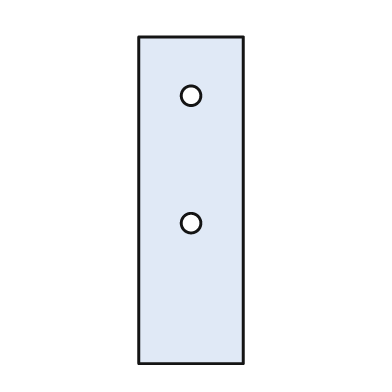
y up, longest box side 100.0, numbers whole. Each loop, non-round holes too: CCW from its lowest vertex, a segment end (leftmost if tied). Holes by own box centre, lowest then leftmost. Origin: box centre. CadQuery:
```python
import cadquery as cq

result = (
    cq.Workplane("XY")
    .moveTo(-16.0, -50.0)
    .lineTo(16.0, -50.0)
    .lineTo(16.0, 50.0)
    .lineTo(-16.0, 50.0)
    .close()
    .moveTo(0.0, -7.0)
    .circle(3.0)
    .moveTo(0.0, 32.0)
    .circle(3.0)
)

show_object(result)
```